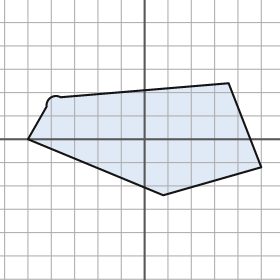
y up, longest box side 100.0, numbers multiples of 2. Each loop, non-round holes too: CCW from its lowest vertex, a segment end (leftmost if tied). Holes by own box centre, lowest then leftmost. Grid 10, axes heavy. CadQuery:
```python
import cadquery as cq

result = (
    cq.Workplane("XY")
    .moveTo(8.0, -24.0)
    .lineTo(50.0, -12.0)
    .lineTo(36.0, 24.0)
    .lineTo(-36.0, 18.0)
    .threePointArc((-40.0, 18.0), (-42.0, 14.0))
    .lineTo(-50.0, 0.0)
    .close()
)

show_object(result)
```